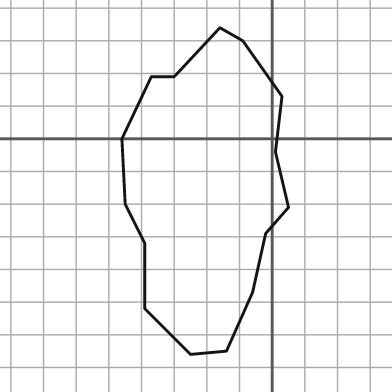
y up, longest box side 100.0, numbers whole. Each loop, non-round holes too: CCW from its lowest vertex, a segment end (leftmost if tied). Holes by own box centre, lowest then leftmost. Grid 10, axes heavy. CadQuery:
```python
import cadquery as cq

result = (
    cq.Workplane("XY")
    .moveTo(-25.0, -66.0)
    .lineTo(-14.0, -65.0)
    .lineTo(-6.0, -47.0)
    .lineTo(-2.0, -29.0)
    .lineTo(5.0, -21.0)
    .lineTo(1.0, -4.0)
    .lineTo(3.0, 13.0)
    .lineTo(-9.0, 30.0)
    .lineTo(-16.0, 34.0)
    .lineTo(-30.0, 19.0)
    .lineTo(-37.0, 19.0)
    .lineTo(-46.0, 0.0)
    .lineTo(-45.0, -20.0)
    .lineTo(-39.0, -32.0)
    .lineTo(-39.0, -52.0)
    .close()
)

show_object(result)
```